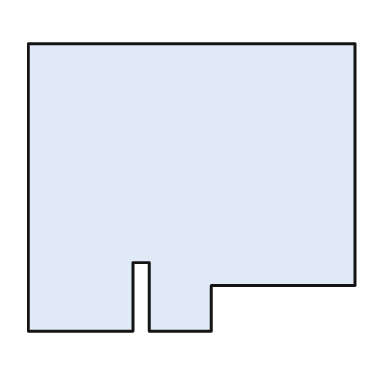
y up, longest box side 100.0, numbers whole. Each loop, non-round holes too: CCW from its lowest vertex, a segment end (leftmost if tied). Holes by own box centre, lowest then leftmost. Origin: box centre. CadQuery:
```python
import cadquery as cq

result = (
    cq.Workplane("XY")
    .moveTo(-50.0, -44.0)
    .lineTo(-18.0, -44.0)
    .lineTo(-18.0, -23.0)
    .lineTo(-13.0, -23.0)
    .lineTo(-13.0, -44.0)
    .lineTo(6.0, -44.0)
    .lineTo(6.0, -30.0)
    .lineTo(50.0, -30.0)
    .lineTo(50.0, 44.0)
    .lineTo(-50.0, 44.0)
    .close()
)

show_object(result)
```